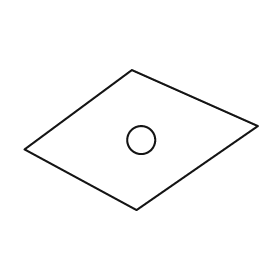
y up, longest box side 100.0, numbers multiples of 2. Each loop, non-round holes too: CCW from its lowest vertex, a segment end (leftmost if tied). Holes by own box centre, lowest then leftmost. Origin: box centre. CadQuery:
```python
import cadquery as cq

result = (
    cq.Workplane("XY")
    .moveTo(-2.0, -30.0)
    .lineTo(50.0, 6.0)
    .lineTo(-4.0, 30.0)
    .lineTo(-50.0, -4.0)
    .close()
    .moveTo(0.0, 0.0)
    .circle(6.0)
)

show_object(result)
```